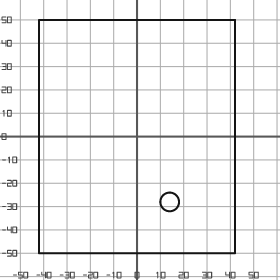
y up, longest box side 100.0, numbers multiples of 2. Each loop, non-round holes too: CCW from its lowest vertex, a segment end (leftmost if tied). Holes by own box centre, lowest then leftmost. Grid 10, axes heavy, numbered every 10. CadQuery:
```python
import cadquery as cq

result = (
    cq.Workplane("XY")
    .moveTo(-42.0, -50.0)
    .lineTo(42.0, -50.0)
    .lineTo(42.0, 50.0)
    .lineTo(-42.0, 50.0)
    .close()
    .moveTo(14.0, -28.0)
    .circle(4.0)
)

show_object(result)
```